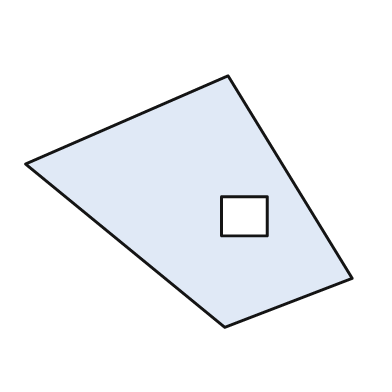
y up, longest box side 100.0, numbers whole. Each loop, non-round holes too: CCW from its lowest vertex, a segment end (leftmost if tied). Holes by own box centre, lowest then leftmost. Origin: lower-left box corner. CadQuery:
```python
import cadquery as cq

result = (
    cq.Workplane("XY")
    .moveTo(61.0, 0.0)
    .lineTo(100.0, 15.0)
    .lineTo(62.0, 77.0)
    .lineTo(0.0, 50.0)
    .close()
    .moveTo(60.0, 28.0)
    .lineTo(74.0, 28.0)
    .lineTo(74.0, 40.0)
    .lineTo(60.0, 40.0)
    .close()
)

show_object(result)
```